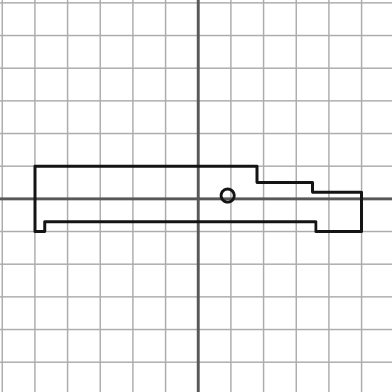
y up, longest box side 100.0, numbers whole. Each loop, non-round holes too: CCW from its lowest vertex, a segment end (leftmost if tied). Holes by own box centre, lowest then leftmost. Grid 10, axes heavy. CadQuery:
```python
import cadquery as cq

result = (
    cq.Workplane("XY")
    .moveTo(-50.0, -10.0)
    .lineTo(-47.0, -10.0)
    .lineTo(-47.0, -7.0)
    .lineTo(36.0, -7.0)
    .lineTo(36.0, -10.0)
    .lineTo(50.0, -10.0)
    .lineTo(50.0, 2.0)
    .lineTo(35.0, 2.0)
    .lineTo(35.0, 5.0)
    .lineTo(18.0, 5.0)
    .lineTo(18.0, 10.0)
    .lineTo(-50.0, 10.0)
    .close()
    .moveTo(9.0, 1.0)
    .circle(2.0)
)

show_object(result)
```